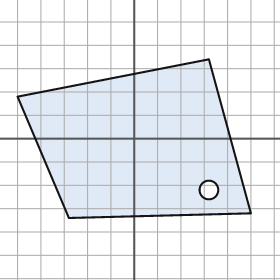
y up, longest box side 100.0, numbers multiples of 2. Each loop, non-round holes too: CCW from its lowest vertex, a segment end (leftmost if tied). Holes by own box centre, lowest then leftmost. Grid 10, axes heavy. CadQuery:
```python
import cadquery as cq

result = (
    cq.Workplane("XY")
    .moveTo(-28.0, -34.0)
    .lineTo(50.0, -32.0)
    .lineTo(32.0, 34.0)
    .lineTo(-50.0, 18.0)
    .close()
    .moveTo(32.0, -22.0)
    .circle(4.0)
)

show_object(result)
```